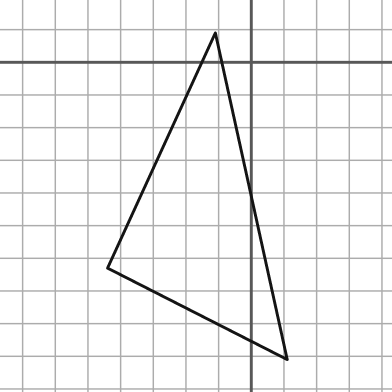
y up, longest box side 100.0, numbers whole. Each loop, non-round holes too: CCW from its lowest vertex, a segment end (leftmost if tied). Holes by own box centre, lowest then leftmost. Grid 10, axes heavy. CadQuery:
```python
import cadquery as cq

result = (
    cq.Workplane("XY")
    .moveTo(11.0, -91.0)
    .lineTo(-11.0, 9.0)
    .lineTo(-44.0, -63.0)
    .close()
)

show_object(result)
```